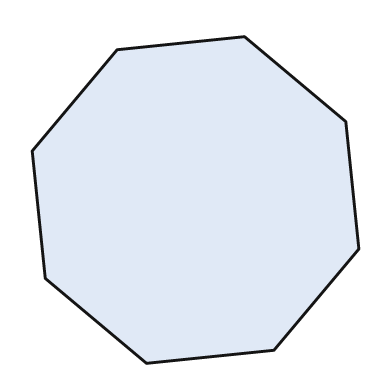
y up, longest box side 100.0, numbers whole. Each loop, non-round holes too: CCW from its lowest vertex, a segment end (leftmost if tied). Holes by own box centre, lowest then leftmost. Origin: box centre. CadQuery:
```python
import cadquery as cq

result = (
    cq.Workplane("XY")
    .moveTo(-15.0, -50.0)
    .lineTo(24.0, -46.0)
    .lineTo(50.0, -15.0)
    .lineTo(46.0, 24.0)
    .lineTo(15.0, 50.0)
    .lineTo(-24.0, 46.0)
    .lineTo(-50.0, 15.0)
    .lineTo(-46.0, -24.0)
    .close()
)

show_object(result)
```